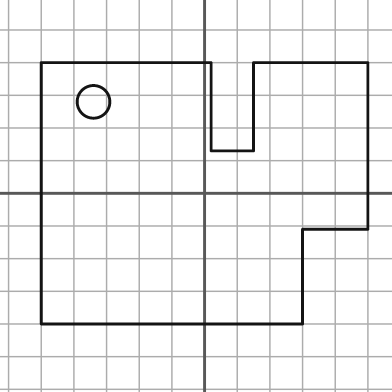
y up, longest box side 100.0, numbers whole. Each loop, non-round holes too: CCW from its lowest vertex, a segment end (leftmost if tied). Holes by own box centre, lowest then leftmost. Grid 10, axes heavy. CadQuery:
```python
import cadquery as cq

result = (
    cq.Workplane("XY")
    .moveTo(-50.0, -40.0)
    .lineTo(30.0, -40.0)
    .lineTo(30.0, -11.0)
    .lineTo(50.0, -11.0)
    .lineTo(50.0, 40.0)
    .lineTo(15.0, 40.0)
    .lineTo(15.0, 13.0)
    .lineTo(2.0, 13.0)
    .lineTo(2.0, 40.0)
    .lineTo(-50.0, 40.0)
    .close()
    .moveTo(-34.0, 28.0)
    .circle(5.0)
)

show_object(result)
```